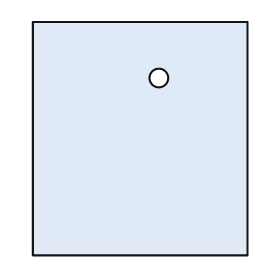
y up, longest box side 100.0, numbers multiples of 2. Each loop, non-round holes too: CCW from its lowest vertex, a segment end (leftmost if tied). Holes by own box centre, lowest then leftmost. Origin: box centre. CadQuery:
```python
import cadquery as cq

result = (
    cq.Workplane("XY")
    .moveTo(-46.0, -50.0)
    .lineTo(46.0, -50.0)
    .lineTo(46.0, 50.0)
    .lineTo(-46.0, 50.0)
    .close()
    .moveTo(8.0, 26.0)
    .circle(4.0)
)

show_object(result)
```